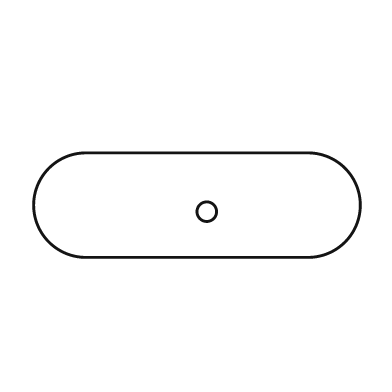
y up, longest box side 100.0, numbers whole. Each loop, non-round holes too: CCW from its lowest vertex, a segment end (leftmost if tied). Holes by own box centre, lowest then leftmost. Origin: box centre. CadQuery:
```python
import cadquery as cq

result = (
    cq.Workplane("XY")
    .moveTo(-34.0, -16.0)
    .lineTo(34.0, -16.0)
    .threePointArc((50.0, 0.0), (34.0, 16.0))
    .lineTo(-34.0, 16.0)
    .threePointArc((-50.0, 0.0), (-34.0, -16.0))
    .close()
    .moveTo(3.0, -2.0)
    .circle(3.0)
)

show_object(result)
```